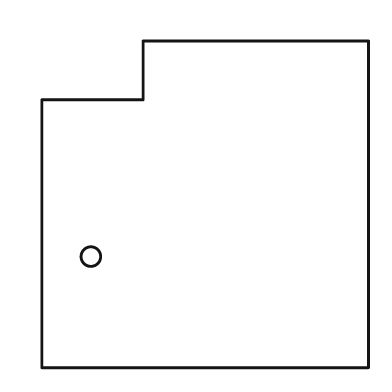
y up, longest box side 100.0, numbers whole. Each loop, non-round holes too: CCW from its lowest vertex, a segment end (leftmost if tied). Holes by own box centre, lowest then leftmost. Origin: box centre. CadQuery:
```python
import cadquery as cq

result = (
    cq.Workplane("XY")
    .moveTo(-50.0, -50.0)
    .lineTo(50.0, -50.0)
    .lineTo(50.0, 50.0)
    .lineTo(-19.0, 50.0)
    .lineTo(-19.0, 32.0)
    .lineTo(-50.0, 32.0)
    .close()
    .moveTo(-35.0, -16.0)
    .circle(3.0)
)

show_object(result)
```